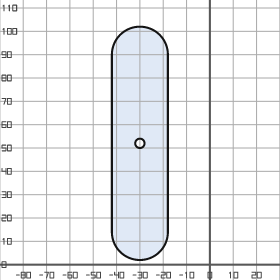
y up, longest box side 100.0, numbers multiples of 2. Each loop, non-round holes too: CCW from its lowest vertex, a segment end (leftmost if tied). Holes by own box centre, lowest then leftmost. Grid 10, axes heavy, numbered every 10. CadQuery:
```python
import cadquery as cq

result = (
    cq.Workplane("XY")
    .moveTo(-42.0, 14.0)
    .threePointArc((-30.0, 2.0), (-18.0, 14.0))
    .lineTo(-18.0, 90.0)
    .threePointArc((-30.0, 102.0), (-42.0, 90.0))
    .close()
    .moveTo(-30.0, 52.0)
    .circle(2.0)
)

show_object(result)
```